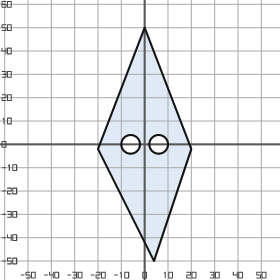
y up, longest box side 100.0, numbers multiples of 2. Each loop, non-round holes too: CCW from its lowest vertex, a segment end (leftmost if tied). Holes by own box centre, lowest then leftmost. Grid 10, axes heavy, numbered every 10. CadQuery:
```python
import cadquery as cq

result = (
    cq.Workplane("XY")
    .moveTo(4.0, -50.0)
    .lineTo(20.0, -2.0)
    .lineTo(0.0, 50.0)
    .lineTo(-20.0, -2.0)
    .close()
    .moveTo(-6.0, 0.0)
    .circle(4.0)
    .moveTo(6.0, 0.0)
    .circle(4.0)
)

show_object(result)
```